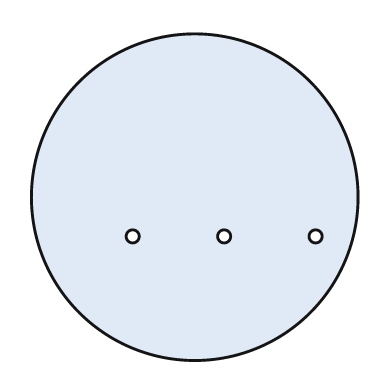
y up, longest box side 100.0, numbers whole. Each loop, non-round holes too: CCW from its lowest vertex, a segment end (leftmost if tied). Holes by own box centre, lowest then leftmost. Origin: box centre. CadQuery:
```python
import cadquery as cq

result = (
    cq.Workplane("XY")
    .moveTo(0.0, 0.0)
    .circle(50.0)
    .moveTo(-19.0, -12.0)
    .circle(2.0)
    .moveTo(9.0, -12.0)
    .circle(2.0)
    .moveTo(37.0, -12.0)
    .circle(2.0)
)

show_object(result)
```